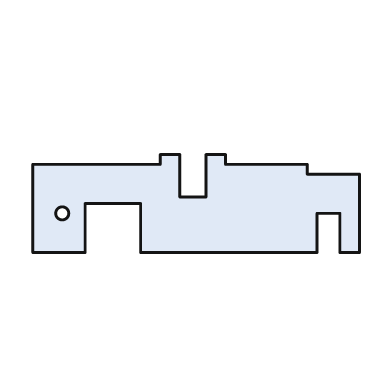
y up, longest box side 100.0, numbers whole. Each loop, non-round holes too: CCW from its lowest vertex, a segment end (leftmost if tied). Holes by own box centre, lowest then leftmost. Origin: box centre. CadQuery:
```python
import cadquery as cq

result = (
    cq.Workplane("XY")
    .moveTo(-50.0, -15.0)
    .lineTo(-34.0, -15.0)
    .lineTo(-34.0, 0.0)
    .lineTo(-17.0, 0.0)
    .lineTo(-17.0, -15.0)
    .lineTo(37.0, -15.0)
    .lineTo(37.0, -3.0)
    .lineTo(44.0, -3.0)
    .lineTo(44.0, -15.0)
    .lineTo(50.0, -15.0)
    .lineTo(50.0, 9.0)
    .lineTo(34.0, 9.0)
    .lineTo(34.0, 12.0)
    .lineTo(9.0, 12.0)
    .lineTo(9.0, 15.0)
    .lineTo(3.0, 15.0)
    .lineTo(3.0, 2.0)
    .lineTo(-5.0, 2.0)
    .lineTo(-5.0, 15.0)
    .lineTo(-11.0, 15.0)
    .lineTo(-11.0, 12.0)
    .lineTo(-50.0, 12.0)
    .close()
    .moveTo(-41.0, -3.0)
    .circle(2.0)
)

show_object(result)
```